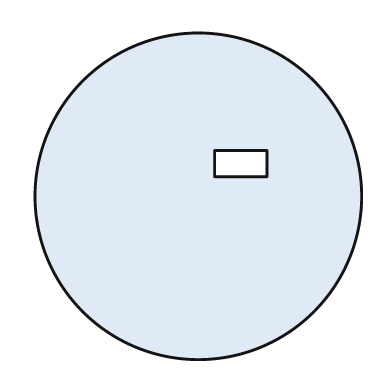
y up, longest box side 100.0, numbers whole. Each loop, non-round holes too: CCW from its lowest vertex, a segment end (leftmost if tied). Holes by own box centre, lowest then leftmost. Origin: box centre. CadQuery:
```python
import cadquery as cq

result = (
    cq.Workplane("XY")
    .moveTo(0.0, 0.0)
    .circle(50.0)
    .moveTo(5.0, 6.0)
    .lineTo(21.0, 6.0)
    .lineTo(21.0, 14.0)
    .lineTo(5.0, 14.0)
    .close()
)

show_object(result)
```